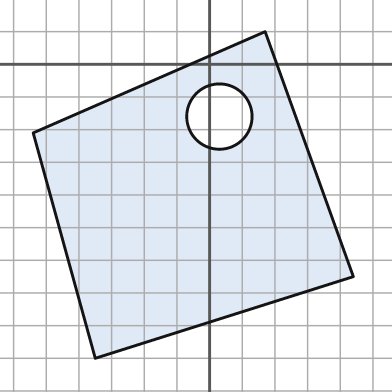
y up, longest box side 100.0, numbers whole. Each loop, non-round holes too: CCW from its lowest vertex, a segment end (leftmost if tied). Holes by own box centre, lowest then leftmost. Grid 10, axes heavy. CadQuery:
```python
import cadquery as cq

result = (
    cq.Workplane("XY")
    .moveTo(-35.0, -90.0)
    .lineTo(44.0, -65.0)
    .lineTo(17.0, 10.0)
    .lineTo(-54.0, -21.0)
    .close()
    .moveTo(3.0, -16.0)
    .circle(10.0)
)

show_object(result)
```